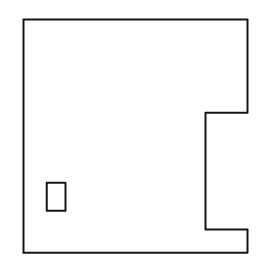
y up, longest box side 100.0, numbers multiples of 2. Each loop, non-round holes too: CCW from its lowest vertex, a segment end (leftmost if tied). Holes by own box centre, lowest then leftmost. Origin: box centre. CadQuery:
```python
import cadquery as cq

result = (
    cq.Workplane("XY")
    .moveTo(-48.0, -50.0)
    .lineTo(48.0, -50.0)
    .lineTo(48.0, -40.0)
    .lineTo(30.0, -40.0)
    .lineTo(30.0, 10.0)
    .lineTo(48.0, 10.0)
    .lineTo(48.0, 50.0)
    .lineTo(-48.0, 50.0)
    .close()
    .moveTo(-38.0, -32.0)
    .lineTo(-30.0, -32.0)
    .lineTo(-30.0, -20.0)
    .lineTo(-38.0, -20.0)
    .close()
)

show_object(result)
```